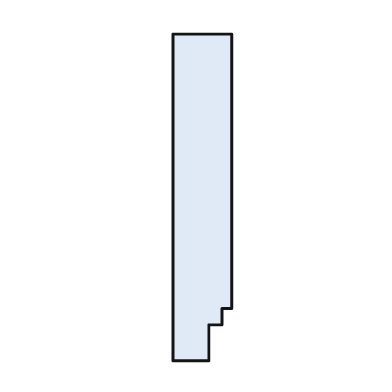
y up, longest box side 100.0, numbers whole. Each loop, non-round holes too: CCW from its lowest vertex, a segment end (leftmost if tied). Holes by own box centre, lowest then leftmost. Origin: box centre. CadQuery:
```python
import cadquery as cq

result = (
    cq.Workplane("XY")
    .moveTo(-9.0, -50.0)
    .lineTo(2.0, -50.0)
    .lineTo(2.0, -39.0)
    .lineTo(6.0, -39.0)
    .lineTo(6.0, -34.0)
    .lineTo(9.0, -34.0)
    .lineTo(9.0, 50.0)
    .lineTo(-9.0, 50.0)
    .close()
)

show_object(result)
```